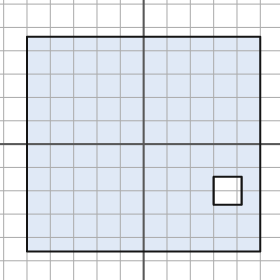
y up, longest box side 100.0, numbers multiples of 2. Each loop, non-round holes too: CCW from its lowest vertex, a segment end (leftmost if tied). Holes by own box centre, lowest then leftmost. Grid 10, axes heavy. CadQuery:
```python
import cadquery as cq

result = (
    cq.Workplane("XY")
    .moveTo(-50.0, -46.0)
    .lineTo(50.0, -46.0)
    .lineTo(50.0, 46.0)
    .lineTo(-50.0, 46.0)
    .close()
    .moveTo(30.0, -26.0)
    .lineTo(42.0, -26.0)
    .lineTo(42.0, -14.0)
    .lineTo(30.0, -14.0)
    .close()
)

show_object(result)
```